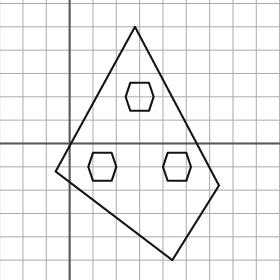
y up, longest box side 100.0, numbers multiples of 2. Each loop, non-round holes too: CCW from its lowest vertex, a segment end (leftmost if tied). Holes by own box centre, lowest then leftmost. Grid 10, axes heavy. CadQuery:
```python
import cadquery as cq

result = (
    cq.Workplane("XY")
    .moveTo(44.0, -50.0)
    .lineTo(64.0, -18.0)
    .lineTo(28.0, 50.0)
    .lineTo(-6.0, -12.0)
    .close()
    .moveTo(10.0, -16.0)
    .lineTo(18.0, -16.0)
    .lineTo(20.0, -10.0)
    .lineTo(18.0, -4.0)
    .lineTo(10.0, -4.0)
    .lineTo(8.0, -10.0)
    .close()
    .moveTo(42.0, -16.0)
    .lineTo(50.0, -16.0)
    .lineTo(52.0, -10.0)
    .lineTo(50.0, -4.0)
    .lineTo(42.0, -4.0)
    .lineTo(40.0, -10.0)
    .close()
    .moveTo(26.0, 14.0)
    .lineTo(34.0, 14.0)
    .lineTo(36.0, 20.0)
    .lineTo(34.0, 26.0)
    .lineTo(26.0, 26.0)
    .lineTo(24.0, 20.0)
    .close()
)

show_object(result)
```